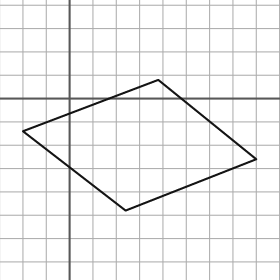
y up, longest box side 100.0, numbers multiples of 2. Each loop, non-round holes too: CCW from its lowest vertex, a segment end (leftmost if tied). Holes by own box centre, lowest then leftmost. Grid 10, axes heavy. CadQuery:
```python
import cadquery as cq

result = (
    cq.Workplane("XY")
    .moveTo(24.0, -48.0)
    .lineTo(80.0, -26.0)
    .lineTo(38.0, 8.0)
    .lineTo(-20.0, -14.0)
    .close()
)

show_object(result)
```